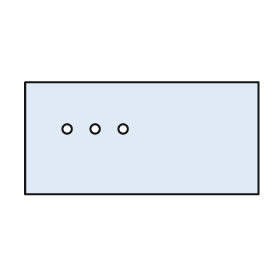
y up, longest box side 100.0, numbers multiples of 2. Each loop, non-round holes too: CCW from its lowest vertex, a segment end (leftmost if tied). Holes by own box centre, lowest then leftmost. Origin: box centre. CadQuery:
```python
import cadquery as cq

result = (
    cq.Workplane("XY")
    .moveTo(-50.0, -24.0)
    .lineTo(50.0, -24.0)
    .lineTo(50.0, 24.0)
    .lineTo(-50.0, 24.0)
    .close()
    .moveTo(-32.0, 4.0)
    .circle(2.0)
    .moveTo(-20.0, 4.0)
    .circle(2.0)
    .moveTo(-8.0, 4.0)
    .circle(2.0)
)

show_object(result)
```